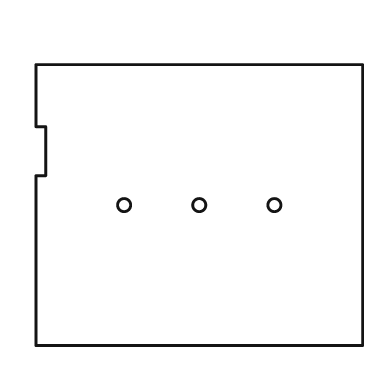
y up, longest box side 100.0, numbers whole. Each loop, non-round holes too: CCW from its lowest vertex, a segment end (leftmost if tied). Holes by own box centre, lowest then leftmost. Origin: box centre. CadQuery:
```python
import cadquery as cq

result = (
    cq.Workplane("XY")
    .moveTo(-50.0, -43.0)
    .lineTo(50.0, -43.0)
    .lineTo(50.0, 43.0)
    .lineTo(-50.0, 43.0)
    .lineTo(-50.0, 24.0)
    .lineTo(-47.0, 24.0)
    .lineTo(-47.0, 9.0)
    .lineTo(-50.0, 9.0)
    .close()
    .moveTo(-23.0, 0.0)
    .circle(2.0)
    .moveTo(0.0, 0.0)
    .circle(2.0)
    .moveTo(23.0, 0.0)
    .circle(2.0)
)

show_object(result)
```